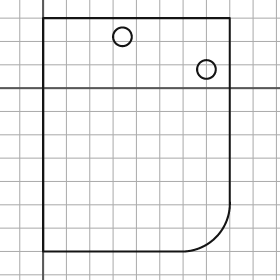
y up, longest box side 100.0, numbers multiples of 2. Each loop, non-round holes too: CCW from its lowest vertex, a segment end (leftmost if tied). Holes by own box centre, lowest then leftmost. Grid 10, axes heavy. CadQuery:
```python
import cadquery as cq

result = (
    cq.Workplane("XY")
    .moveTo(0.0, -70.0)
    .lineTo(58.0, -70.0)
    .threePointArc((74.0, -64.0), (80.0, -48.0))
    .lineTo(80.0, 30.0)
    .lineTo(0.0, 30.0)
    .close()
    .moveTo(70.0, 8.0)
    .circle(4.0)
    .moveTo(34.0, 22.0)
    .circle(4.0)
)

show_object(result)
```